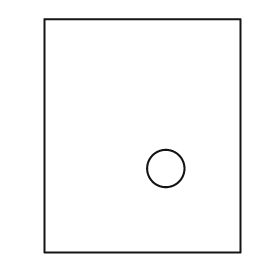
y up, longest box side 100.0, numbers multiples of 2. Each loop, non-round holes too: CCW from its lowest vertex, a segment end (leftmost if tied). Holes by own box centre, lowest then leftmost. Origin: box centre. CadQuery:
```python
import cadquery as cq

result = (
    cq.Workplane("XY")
    .moveTo(-42.0, -50.0)
    .lineTo(42.0, -50.0)
    .lineTo(42.0, 50.0)
    .lineTo(-42.0, 50.0)
    .close()
    .moveTo(10.0, -14.0)
    .circle(8.0)
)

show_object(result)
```